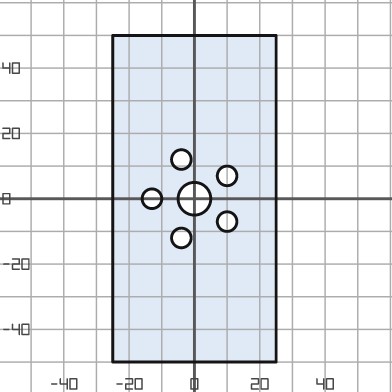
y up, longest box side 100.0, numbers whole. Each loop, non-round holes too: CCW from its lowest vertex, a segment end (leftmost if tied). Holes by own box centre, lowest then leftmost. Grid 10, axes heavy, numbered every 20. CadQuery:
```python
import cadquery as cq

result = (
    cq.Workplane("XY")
    .moveTo(-25.0, -50.0)
    .lineTo(25.0, -50.0)
    .lineTo(25.0, 50.0)
    .lineTo(-25.0, 50.0)
    .close()
    .moveTo(-4.0, -12.0)
    .circle(3.0)
    .moveTo(10.0, -7.0)
    .circle(3.0)
    .moveTo(-13.0, 0.0)
    .circle(3.0)
    .moveTo(0.0, 0.0)
    .circle(5.0)
    .moveTo(10.0, 7.0)
    .circle(3.0)
    .moveTo(-4.0, 12.0)
    .circle(3.0)
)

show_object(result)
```